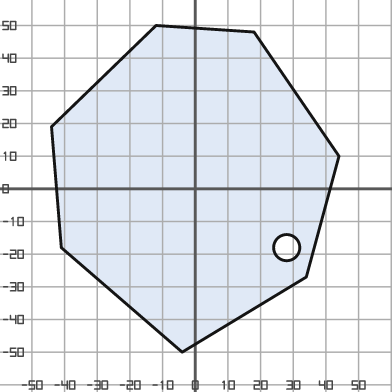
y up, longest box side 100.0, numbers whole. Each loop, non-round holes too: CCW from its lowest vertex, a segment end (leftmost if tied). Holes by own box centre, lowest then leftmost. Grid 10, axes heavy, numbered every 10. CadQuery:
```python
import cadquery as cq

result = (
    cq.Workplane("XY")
    .moveTo(-4.0, -50.0)
    .lineTo(34.0, -27.0)
    .lineTo(44.0, 10.0)
    .lineTo(18.0, 48.0)
    .lineTo(-12.0, 50.0)
    .lineTo(-44.0, 19.0)
    .lineTo(-41.0, -18.0)
    .close()
    .moveTo(28.0, -18.0)
    .circle(4.0)
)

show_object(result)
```